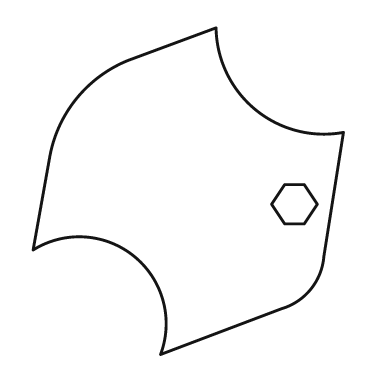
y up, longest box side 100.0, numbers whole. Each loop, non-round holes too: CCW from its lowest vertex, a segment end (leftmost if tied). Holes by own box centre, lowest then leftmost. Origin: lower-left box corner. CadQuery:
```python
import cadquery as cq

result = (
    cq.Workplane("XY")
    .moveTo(39.0, 0.0)
    .lineTo(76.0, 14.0)
    .threePointArc((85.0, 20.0), (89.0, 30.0))
    .lineTo(95.0, 68.0)
    .threePointArc((68.0, 75.0), (56.0, 100.0))
    .lineTo(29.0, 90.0)
    .threePointArc((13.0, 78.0), (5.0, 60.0))
    .lineTo(0.0, 32.0)
    .threePointArc((31.0, 30.0), (39.0, 0.0))
    .close()
    .moveTo(77.0, 40.0)
    .lineTo(83.0, 40.0)
    .lineTo(87.0, 46.0)
    .lineTo(83.0, 52.0)
    .lineTo(77.0, 52.0)
    .lineTo(73.0, 46.0)
    .close()
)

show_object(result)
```